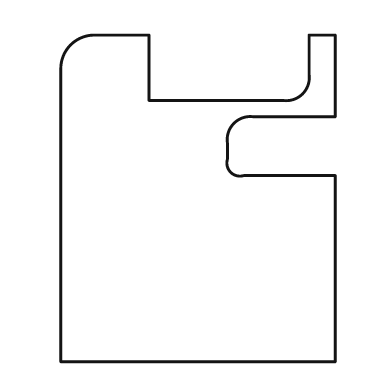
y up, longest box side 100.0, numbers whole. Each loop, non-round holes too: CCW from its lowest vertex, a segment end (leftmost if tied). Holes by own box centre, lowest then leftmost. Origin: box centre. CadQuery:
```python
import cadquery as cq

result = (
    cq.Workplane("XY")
    .moveTo(-42.0, -50.0)
    .lineTo(42.0, -50.0)
    .lineTo(42.0, 7.0)
    .lineTo(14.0, 7.0)
    .threePointArc((10.0, 8.0), (9.0, 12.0))
    .lineTo(9.0, 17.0)
    .threePointArc((11.0, 23.0), (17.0, 25.0))
    .lineTo(42.0, 25.0)
    .lineTo(42.0, 50.0)
    .lineTo(34.0, 50.0)
    .lineTo(34.0, 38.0)
    .threePointArc((32.0, 32.0), (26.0, 30.0))
    .lineTo(-15.0, 30.0)
    .lineTo(-15.0, 50.0)
    .lineTo(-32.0, 50.0)
    .threePointArc((-39.0, 47.0), (-42.0, 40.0))
    .close()
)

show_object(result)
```